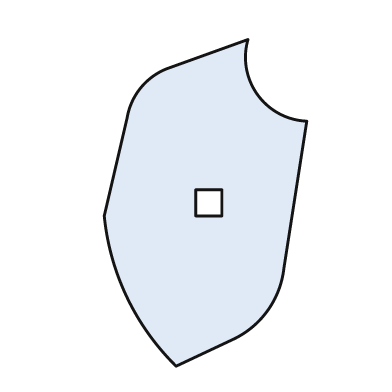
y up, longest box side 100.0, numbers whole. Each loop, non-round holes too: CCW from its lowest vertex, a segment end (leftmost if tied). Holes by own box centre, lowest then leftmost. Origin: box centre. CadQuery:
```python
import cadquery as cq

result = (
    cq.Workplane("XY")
    .moveTo(-9.0, -50.0)
    .lineTo(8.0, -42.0)
    .threePointArc((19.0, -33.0), (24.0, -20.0))
    .lineTo(31.0, 25.0)
    .threePointArc((16.0, 33.0), (13.0, 50.0))
    .lineTo(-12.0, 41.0)
    .threePointArc((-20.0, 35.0), (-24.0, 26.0))
    .lineTo(-31.0, -4.0)
    .threePointArc((-24.0, -29.0), (-9.0, -50.0))
    .close()
    .moveTo(-3.0, -4.0)
    .lineTo(5.0, -4.0)
    .lineTo(5.0, 4.0)
    .lineTo(-3.0, 4.0)
    .close()
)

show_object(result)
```